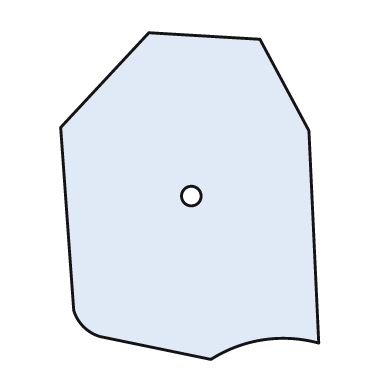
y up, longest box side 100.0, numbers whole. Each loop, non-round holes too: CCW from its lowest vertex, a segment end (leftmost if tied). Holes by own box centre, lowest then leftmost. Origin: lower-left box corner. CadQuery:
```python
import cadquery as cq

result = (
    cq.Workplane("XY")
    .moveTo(46.0, 0.0)
    .threePointArc((62.0, 6.0), (79.0, 5.0))
    .lineTo(76.0, 70.0)
    .lineTo(61.0, 98.0)
    .lineTo(27.0, 100.0)
    .lineTo(0.0, 71.0)
    .lineTo(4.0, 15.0)
    .threePointArc((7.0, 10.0), (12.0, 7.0))
    .close()
    .moveTo(40.0, 50.0)
    .circle(3.0)
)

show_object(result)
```